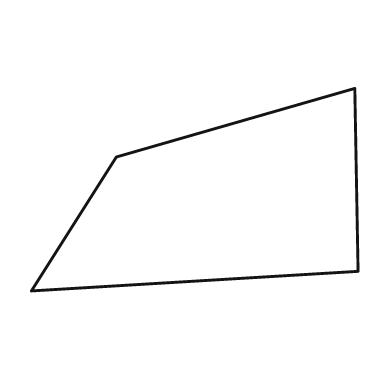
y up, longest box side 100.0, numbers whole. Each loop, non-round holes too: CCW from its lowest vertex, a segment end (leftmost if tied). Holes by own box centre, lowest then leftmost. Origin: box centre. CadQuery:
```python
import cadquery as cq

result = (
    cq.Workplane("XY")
    .moveTo(-50.0, -31.0)
    .lineTo(50.0, -25.0)
    .lineTo(49.0, 31.0)
    .lineTo(-24.0, 10.0)
    .close()
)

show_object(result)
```